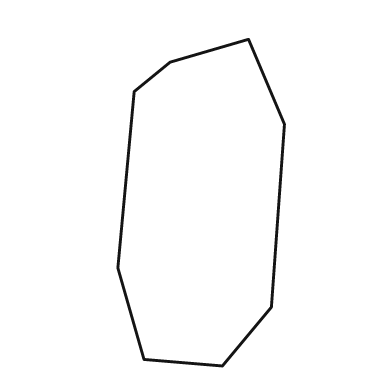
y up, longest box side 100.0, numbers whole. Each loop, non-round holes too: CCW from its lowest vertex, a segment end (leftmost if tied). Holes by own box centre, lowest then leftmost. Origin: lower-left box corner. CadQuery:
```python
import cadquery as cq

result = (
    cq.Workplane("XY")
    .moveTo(32.0, 0.0)
    .lineTo(47.0, 18.0)
    .lineTo(51.0, 74.0)
    .lineTo(40.0, 100.0)
    .lineTo(16.0, 93.0)
    .lineTo(5.0, 84.0)
    .lineTo(0.0, 30.0)
    .lineTo(8.0, 2.0)
    .close()
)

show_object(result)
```